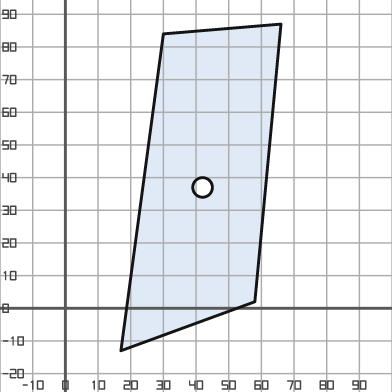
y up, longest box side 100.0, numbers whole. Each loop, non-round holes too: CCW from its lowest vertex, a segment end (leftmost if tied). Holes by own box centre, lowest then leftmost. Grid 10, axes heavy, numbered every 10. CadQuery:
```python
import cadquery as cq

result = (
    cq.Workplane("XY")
    .moveTo(17.0, -13.0)
    .lineTo(58.0, 2.0)
    .lineTo(66.0, 87.0)
    .lineTo(30.0, 84.0)
    .close()
    .moveTo(42.0, 37.0)
    .circle(3.0)
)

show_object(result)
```